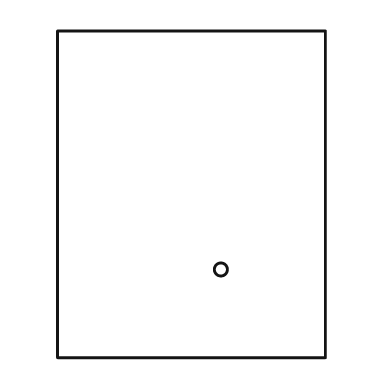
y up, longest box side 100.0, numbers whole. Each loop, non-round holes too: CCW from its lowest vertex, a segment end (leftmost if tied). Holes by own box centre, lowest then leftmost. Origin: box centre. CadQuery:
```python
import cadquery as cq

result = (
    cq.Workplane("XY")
    .moveTo(-41.0, -50.0)
    .lineTo(41.0, -50.0)
    .lineTo(41.0, 50.0)
    .lineTo(-41.0, 50.0)
    .close()
    .moveTo(9.0, -23.0)
    .circle(2.0)
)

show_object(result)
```